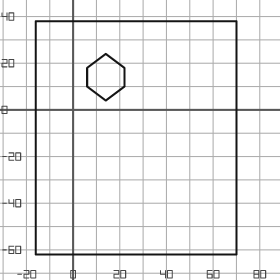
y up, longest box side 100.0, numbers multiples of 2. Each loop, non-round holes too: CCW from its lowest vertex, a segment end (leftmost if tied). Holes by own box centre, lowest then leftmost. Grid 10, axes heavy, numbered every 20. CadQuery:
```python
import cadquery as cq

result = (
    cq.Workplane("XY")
    .moveTo(-16.0, -62.0)
    .lineTo(70.0, -62.0)
    .lineTo(70.0, 38.0)
    .lineTo(-16.0, 38.0)
    .close()
    .moveTo(14.0, 4.0)
    .lineTo(22.0, 10.0)
    .lineTo(22.0, 18.0)
    .lineTo(14.0, 24.0)
    .lineTo(6.0, 18.0)
    .lineTo(6.0, 10.0)
    .close()
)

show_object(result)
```